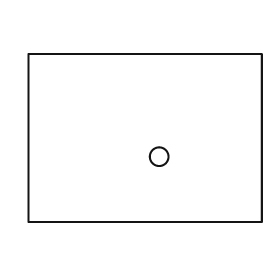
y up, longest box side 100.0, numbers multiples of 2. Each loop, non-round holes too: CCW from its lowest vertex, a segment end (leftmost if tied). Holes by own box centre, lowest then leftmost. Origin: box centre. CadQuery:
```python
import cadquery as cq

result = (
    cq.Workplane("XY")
    .moveTo(-50.0, -36.0)
    .lineTo(50.0, -36.0)
    .lineTo(50.0, 36.0)
    .lineTo(-50.0, 36.0)
    .close()
    .moveTo(6.0, -8.0)
    .circle(4.0)
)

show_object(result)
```